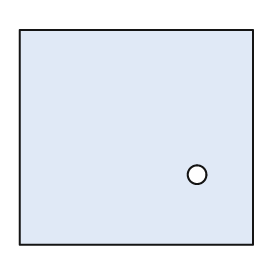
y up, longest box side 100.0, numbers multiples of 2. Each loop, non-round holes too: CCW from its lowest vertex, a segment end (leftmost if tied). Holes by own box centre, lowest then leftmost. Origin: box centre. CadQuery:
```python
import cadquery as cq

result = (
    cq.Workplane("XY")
    .moveTo(-50.0, -46.0)
    .lineTo(50.0, -46.0)
    .lineTo(50.0, 46.0)
    .lineTo(-50.0, 46.0)
    .close()
    .moveTo(26.0, -16.0)
    .circle(4.0)
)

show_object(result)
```